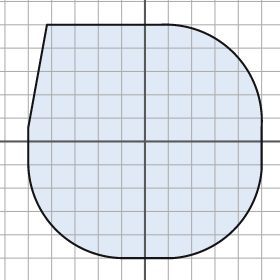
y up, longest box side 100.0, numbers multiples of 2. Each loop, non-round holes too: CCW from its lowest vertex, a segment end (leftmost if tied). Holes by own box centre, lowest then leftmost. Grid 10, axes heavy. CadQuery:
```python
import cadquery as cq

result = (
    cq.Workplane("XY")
    .moveTo(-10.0, -50.0)
    .lineTo(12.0, -50.0)
    .threePointArc((38.0, -38.0), (50.0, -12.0))
    .lineTo(50.0, 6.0)
    .threePointArc((38.0, 38.0), (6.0, 50.0))
    .lineTo(-42.0, 50.0)
    .lineTo(-50.0, 6.0)
    .lineTo(-50.0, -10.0)
    .threePointArc((-38.0, -38.0), (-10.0, -50.0))
    .close()
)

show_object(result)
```